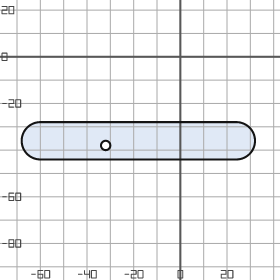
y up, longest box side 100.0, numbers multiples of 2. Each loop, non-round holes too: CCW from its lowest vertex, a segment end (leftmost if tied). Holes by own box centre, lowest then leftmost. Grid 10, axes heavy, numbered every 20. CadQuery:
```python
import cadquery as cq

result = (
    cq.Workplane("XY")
    .moveTo(-60.0, -44.0)
    .lineTo(24.0, -44.0)
    .threePointArc((32.0, -36.0), (24.0, -28.0))
    .lineTo(-60.0, -28.0)
    .threePointArc((-68.0, -36.0), (-60.0, -44.0))
    .close()
    .moveTo(-32.0, -38.0)
    .circle(2.0)
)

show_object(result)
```